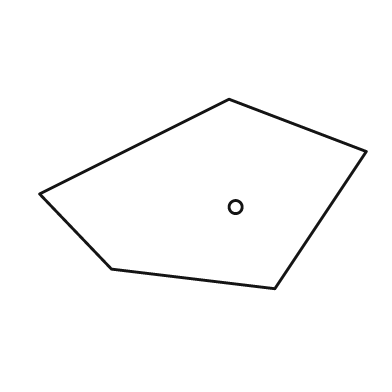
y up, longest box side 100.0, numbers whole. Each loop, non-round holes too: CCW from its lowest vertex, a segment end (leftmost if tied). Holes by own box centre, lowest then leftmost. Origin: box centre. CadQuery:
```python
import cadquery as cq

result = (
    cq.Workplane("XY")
    .moveTo(22.0, -29.0)
    .lineTo(50.0, 13.0)
    .lineTo(8.0, 29.0)
    .lineTo(-50.0, 0.0)
    .lineTo(-28.0, -23.0)
    .close()
    .moveTo(10.0, -4.0)
    .circle(2.0)
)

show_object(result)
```